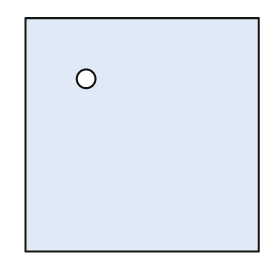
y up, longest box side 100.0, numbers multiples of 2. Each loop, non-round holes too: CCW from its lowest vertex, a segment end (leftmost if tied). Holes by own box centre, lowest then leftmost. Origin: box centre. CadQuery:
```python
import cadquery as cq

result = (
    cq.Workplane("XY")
    .moveTo(-50.0, -50.0)
    .lineTo(50.0, -50.0)
    .lineTo(50.0, 50.0)
    .lineTo(-50.0, 50.0)
    .close()
    .moveTo(-24.0, 24.0)
    .circle(4.0)
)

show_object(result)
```